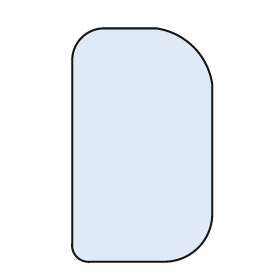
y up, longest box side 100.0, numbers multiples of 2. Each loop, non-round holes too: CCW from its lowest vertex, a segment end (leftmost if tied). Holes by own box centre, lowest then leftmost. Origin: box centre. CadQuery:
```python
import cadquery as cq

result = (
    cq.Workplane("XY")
    .moveTo(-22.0, -50.0)
    .lineTo(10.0, -50.0)
    .threePointArc((24.0, -44.0), (30.0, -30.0))
    .lineTo(30.0, 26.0)
    .threePointArc((22.0, 42.0), (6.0, 50.0))
    .lineTo(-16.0, 50.0)
    .threePointArc((-26.0, 46.0), (-30.0, 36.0))
    .lineTo(-30.0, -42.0)
    .threePointArc((-28.0, -48.0), (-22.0, -50.0))
    .close()
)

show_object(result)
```